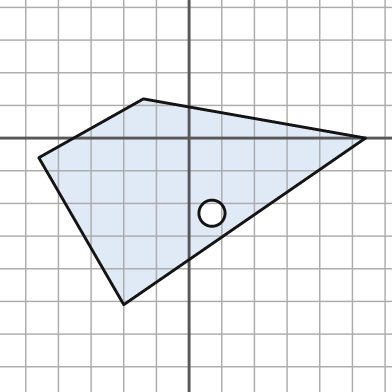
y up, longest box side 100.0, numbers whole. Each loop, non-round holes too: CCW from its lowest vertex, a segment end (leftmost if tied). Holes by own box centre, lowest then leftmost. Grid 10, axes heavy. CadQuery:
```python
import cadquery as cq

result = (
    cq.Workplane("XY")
    .moveTo(-20.0, -51.0)
    .lineTo(54.0, 0.0)
    .lineTo(-14.0, 12.0)
    .lineTo(-46.0, -6.0)
    .close()
    .moveTo(7.0, -23.0)
    .circle(4.0)
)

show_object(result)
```